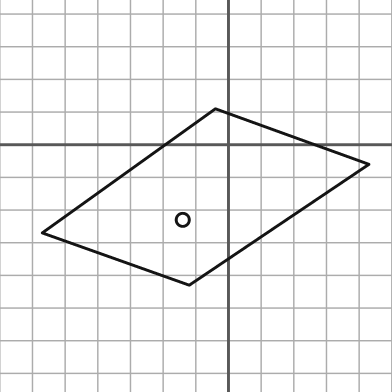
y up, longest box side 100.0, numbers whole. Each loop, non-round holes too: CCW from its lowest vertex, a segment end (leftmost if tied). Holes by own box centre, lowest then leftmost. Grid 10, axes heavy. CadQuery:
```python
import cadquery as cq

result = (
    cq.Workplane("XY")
    .moveTo(-12.0, -43.0)
    .lineTo(43.0, -6.0)
    .lineTo(-4.0, 11.0)
    .lineTo(-57.0, -27.0)
    .close()
    .moveTo(-14.0, -23.0)
    .circle(2.0)
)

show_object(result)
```